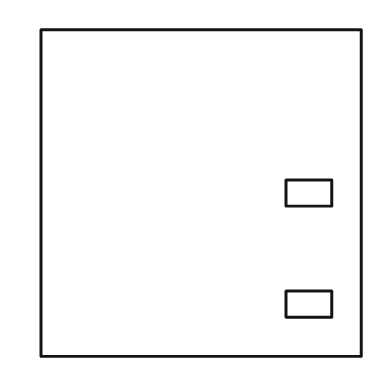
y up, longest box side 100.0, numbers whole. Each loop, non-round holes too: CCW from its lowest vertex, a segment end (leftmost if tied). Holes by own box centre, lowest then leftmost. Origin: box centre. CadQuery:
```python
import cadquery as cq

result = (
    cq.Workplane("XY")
    .moveTo(-49.0, -50.0)
    .lineTo(49.0, -50.0)
    .lineTo(49.0, 50.0)
    .lineTo(-49.0, 50.0)
    .close()
    .moveTo(26.0, -38.0)
    .lineTo(40.0, -38.0)
    .lineTo(40.0, -30.0)
    .lineTo(26.0, -30.0)
    .close()
    .moveTo(26.0, -4.0)
    .lineTo(40.0, -4.0)
    .lineTo(40.0, 4.0)
    .lineTo(26.0, 4.0)
    .close()
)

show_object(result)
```